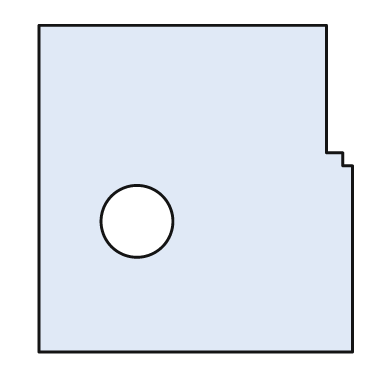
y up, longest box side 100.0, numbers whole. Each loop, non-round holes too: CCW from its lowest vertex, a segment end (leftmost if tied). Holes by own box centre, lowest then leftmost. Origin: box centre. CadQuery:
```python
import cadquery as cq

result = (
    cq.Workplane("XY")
    .moveTo(-48.0, -50.0)
    .lineTo(48.0, -50.0)
    .lineTo(48.0, 7.0)
    .lineTo(45.0, 7.0)
    .lineTo(45.0, 11.0)
    .lineTo(40.0, 11.0)
    .lineTo(40.0, 50.0)
    .lineTo(-48.0, 50.0)
    .close()
    .moveTo(-18.0, -10.0)
    .circle(11.0)
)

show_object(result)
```